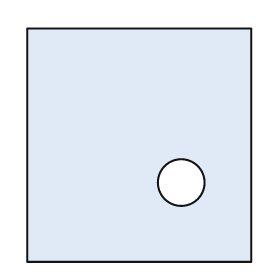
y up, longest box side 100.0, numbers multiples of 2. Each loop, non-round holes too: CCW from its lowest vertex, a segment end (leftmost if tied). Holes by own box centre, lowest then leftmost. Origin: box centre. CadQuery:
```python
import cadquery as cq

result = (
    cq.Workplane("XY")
    .moveTo(-48.0, -50.0)
    .lineTo(48.0, -50.0)
    .lineTo(48.0, 50.0)
    .lineTo(-48.0, 50.0)
    .close()
    .moveTo(18.0, -16.0)
    .circle(10.0)
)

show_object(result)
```